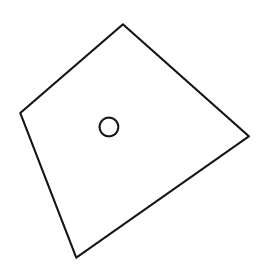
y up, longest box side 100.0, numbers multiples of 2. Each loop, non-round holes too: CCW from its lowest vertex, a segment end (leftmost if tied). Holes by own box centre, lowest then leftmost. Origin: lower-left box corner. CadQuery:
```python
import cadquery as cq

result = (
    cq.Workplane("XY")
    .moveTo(24.0, 0.0)
    .lineTo(98.0, 52.0)
    .lineTo(44.0, 100.0)
    .lineTo(0.0, 62.0)
    .close()
    .moveTo(38.0, 56.0)
    .circle(4.0)
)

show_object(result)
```